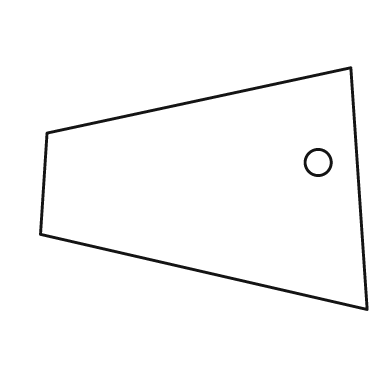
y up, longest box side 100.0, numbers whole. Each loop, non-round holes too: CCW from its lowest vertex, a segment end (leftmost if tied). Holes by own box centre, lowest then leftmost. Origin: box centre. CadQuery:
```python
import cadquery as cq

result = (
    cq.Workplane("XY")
    .moveTo(50.0, -37.0)
    .lineTo(45.0, 37.0)
    .lineTo(-48.0, 17.0)
    .lineTo(-50.0, -14.0)
    .close()
    .moveTo(35.0, 8.0)
    .circle(4.0)
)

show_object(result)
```